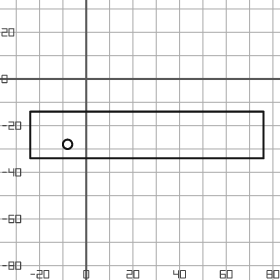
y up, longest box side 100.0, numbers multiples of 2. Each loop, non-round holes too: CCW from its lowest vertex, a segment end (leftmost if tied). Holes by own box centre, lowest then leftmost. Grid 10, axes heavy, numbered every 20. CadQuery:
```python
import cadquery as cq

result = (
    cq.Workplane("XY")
    .moveTo(-24.0, -34.0)
    .lineTo(76.0, -34.0)
    .lineTo(76.0, -14.0)
    .lineTo(-24.0, -14.0)
    .close()
    .moveTo(-8.0, -28.0)
    .circle(2.0)
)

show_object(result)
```